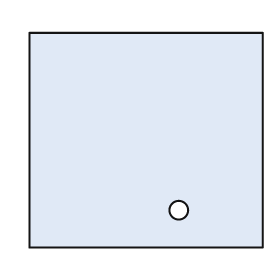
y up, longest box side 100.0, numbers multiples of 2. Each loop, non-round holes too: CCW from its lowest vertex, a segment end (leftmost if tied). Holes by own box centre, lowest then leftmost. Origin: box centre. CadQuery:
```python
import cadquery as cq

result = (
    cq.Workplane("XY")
    .moveTo(-50.0, -46.0)
    .lineTo(50.0, -46.0)
    .lineTo(50.0, 46.0)
    .lineTo(-50.0, 46.0)
    .close()
    .moveTo(14.0, -30.0)
    .circle(4.0)
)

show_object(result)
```